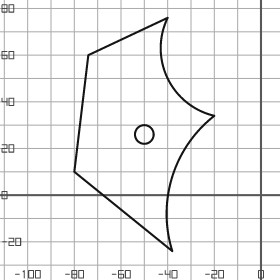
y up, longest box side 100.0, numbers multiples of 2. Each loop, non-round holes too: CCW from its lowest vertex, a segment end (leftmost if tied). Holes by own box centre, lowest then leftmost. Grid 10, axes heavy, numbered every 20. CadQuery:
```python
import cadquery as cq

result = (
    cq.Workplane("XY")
    .moveTo(-38.0, -24.0)
    .threePointArc((-38.0, 8.0), (-20.0, 34.0))
    .threePointArc((-40.0, 50.0), (-40.0, 76.0))
    .lineTo(-74.0, 60.0)
    .lineTo(-80.0, 10.0)
    .close()
    .moveTo(-50.0, 26.0)
    .circle(4.0)
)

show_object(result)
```